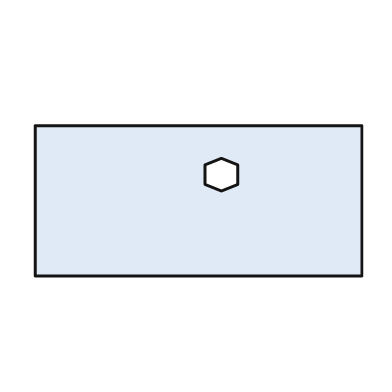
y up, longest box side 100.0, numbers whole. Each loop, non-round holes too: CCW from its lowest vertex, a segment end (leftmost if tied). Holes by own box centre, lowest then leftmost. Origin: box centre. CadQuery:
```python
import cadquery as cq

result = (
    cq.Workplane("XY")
    .moveTo(-50.0, -23.0)
    .lineTo(50.0, -23.0)
    .lineTo(50.0, 23.0)
    .lineTo(-50.0, 23.0)
    .close()
    .moveTo(7.0, 3.0)
    .lineTo(12.0, 5.0)
    .lineTo(12.0, 11.0)
    .lineTo(7.0, 13.0)
    .lineTo(2.0, 11.0)
    .lineTo(2.0, 5.0)
    .close()
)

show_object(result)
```